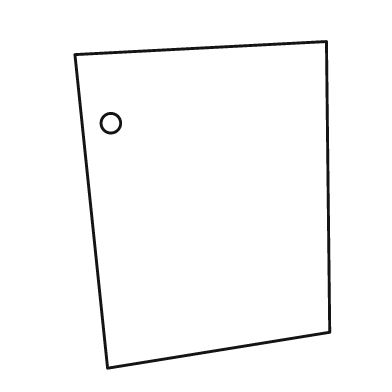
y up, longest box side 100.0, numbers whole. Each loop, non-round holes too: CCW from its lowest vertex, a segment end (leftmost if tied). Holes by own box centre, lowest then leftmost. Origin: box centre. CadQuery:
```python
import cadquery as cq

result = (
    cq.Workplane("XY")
    .moveTo(-29.0, -50.0)
    .lineTo(39.0, -39.0)
    .lineTo(38.0, 50.0)
    .lineTo(-39.0, 46.0)
    .close()
    .moveTo(-28.0, 25.0)
    .circle(3.0)
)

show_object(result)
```